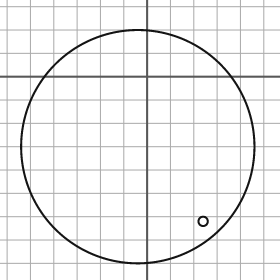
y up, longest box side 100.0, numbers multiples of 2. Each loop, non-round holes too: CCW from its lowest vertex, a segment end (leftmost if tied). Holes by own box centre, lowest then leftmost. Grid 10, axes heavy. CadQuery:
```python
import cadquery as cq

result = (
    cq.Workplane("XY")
    .moveTo(-4.0, -30.0)
    .circle(50.0)
    .moveTo(24.0, -62.0)
    .circle(2.0)
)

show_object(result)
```